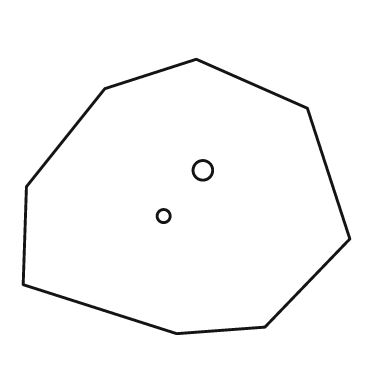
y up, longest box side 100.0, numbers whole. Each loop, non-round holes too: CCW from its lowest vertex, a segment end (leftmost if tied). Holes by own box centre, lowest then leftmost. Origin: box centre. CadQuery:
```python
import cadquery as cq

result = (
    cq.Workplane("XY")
    .moveTo(-3.0, -42.0)
    .lineTo(24.0, -40.0)
    .lineTo(50.0, -13.0)
    .lineTo(37.0, 27.0)
    .lineTo(3.0, 42.0)
    .lineTo(-25.0, 33.0)
    .lineTo(-49.0, 3.0)
    .lineTo(-50.0, -27.0)
    .close()
    .moveTo(-7.0, -6.0)
    .circle(2.0)
    .moveTo(5.0, 8.0)
    .circle(3.0)
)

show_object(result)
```